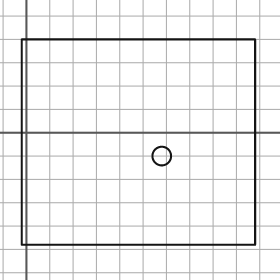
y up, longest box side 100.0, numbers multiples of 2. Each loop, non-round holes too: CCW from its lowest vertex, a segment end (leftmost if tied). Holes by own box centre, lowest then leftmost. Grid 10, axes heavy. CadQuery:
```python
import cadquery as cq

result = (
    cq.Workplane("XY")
    .moveTo(-2.0, -48.0)
    .lineTo(98.0, -48.0)
    .lineTo(98.0, 40.0)
    .lineTo(-2.0, 40.0)
    .close()
    .moveTo(58.0, -10.0)
    .circle(4.0)
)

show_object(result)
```